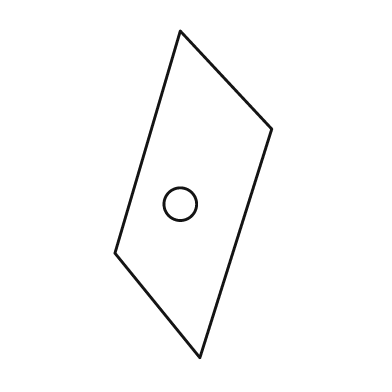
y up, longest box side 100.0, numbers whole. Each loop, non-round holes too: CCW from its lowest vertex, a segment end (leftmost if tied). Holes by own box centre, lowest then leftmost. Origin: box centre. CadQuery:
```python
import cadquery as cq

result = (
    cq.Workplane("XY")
    .moveTo(2.0, -50.0)
    .lineTo(24.0, 20.0)
    .lineTo(-4.0, 50.0)
    .lineTo(-24.0, -18.0)
    .close()
    .moveTo(-4.0, -3.0)
    .circle(5.0)
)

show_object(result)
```